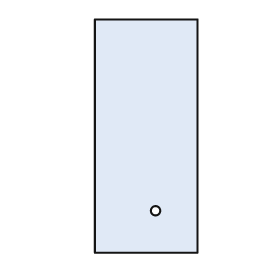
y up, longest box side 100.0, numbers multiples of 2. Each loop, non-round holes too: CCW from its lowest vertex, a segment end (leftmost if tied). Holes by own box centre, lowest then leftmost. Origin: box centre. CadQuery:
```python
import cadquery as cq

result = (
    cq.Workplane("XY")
    .moveTo(-22.0, -50.0)
    .lineTo(22.0, -50.0)
    .lineTo(22.0, 50.0)
    .lineTo(-22.0, 50.0)
    .close()
    .moveTo(4.0, -32.0)
    .circle(2.0)
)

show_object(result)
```